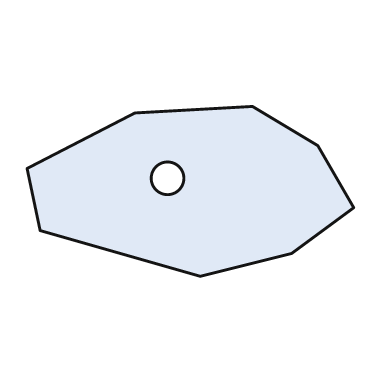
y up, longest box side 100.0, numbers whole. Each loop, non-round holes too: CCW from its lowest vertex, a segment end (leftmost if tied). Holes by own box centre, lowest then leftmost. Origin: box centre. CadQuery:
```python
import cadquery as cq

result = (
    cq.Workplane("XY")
    .moveTo(3.0, -26.0)
    .lineTo(31.0, -19.0)
    .lineTo(50.0, -5.0)
    .lineTo(39.0, 14.0)
    .lineTo(19.0, 26.0)
    .lineTo(-17.0, 24.0)
    .lineTo(-50.0, 7.0)
    .lineTo(-46.0, -12.0)
    .close()
    .moveTo(-7.0, 4.0)
    .circle(5.0)
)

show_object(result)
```